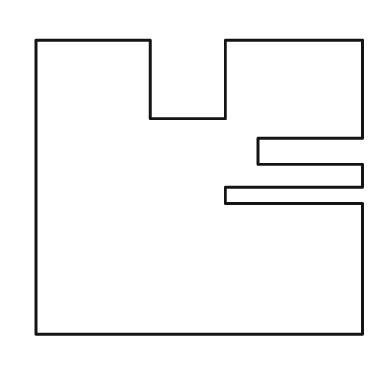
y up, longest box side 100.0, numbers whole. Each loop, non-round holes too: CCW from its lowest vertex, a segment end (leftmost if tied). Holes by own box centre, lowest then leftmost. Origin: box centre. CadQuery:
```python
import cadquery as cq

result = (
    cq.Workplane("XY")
    .moveTo(-50.0, -45.0)
    .lineTo(50.0, -45.0)
    .lineTo(50.0, -5.0)
    .lineTo(8.0, -5.0)
    .lineTo(8.0, 0.0)
    .lineTo(50.0, 0.0)
    .lineTo(50.0, 7.0)
    .lineTo(18.0, 7.0)
    .lineTo(18.0, 15.0)
    .lineTo(50.0, 15.0)
    .lineTo(50.0, 45.0)
    .lineTo(8.0, 45.0)
    .lineTo(8.0, 21.0)
    .lineTo(-15.0, 21.0)
    .lineTo(-15.0, 45.0)
    .lineTo(-50.0, 45.0)
    .close()
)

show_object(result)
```